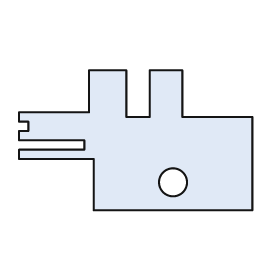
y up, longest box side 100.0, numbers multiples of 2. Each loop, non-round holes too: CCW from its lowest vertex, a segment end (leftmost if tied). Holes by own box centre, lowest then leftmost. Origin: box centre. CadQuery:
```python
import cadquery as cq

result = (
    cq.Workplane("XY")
    .moveTo(-18.0, -30.0)
    .lineTo(50.0, -30.0)
    .lineTo(50.0, 10.0)
    .lineTo(20.0, 10.0)
    .lineTo(20.0, 30.0)
    .lineTo(6.0, 30.0)
    .lineTo(6.0, 10.0)
    .lineTo(-4.0, 10.0)
    .lineTo(-4.0, 30.0)
    .lineTo(-20.0, 30.0)
    .lineTo(-20.0, 12.0)
    .lineTo(-50.0, 12.0)
    .lineTo(-50.0, 8.0)
    .lineTo(-46.0, 8.0)
    .lineTo(-46.0, 4.0)
    .lineTo(-50.0, 4.0)
    .lineTo(-50.0, 0.0)
    .lineTo(-22.0, 0.0)
    .lineTo(-22.0, -4.0)
    .lineTo(-50.0, -4.0)
    .lineTo(-50.0, -8.0)
    .lineTo(-18.0, -8.0)
    .close()
    .moveTo(16.0, -18.0)
    .circle(6.0)
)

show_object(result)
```